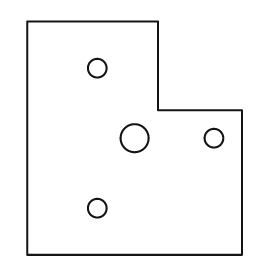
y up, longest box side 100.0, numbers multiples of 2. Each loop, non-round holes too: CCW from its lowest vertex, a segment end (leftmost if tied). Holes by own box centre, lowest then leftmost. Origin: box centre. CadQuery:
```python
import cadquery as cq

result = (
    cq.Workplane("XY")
    .moveTo(-46.0, -50.0)
    .lineTo(46.0, -50.0)
    .lineTo(46.0, 12.0)
    .lineTo(10.0, 12.0)
    .lineTo(10.0, 50.0)
    .lineTo(-46.0, 50.0)
    .close()
    .moveTo(-16.0, -30.0)
    .circle(4.0)
    .moveTo(0.0, 0.0)
    .circle(6.0)
    .moveTo(34.0, 0.0)
    .circle(4.0)
    .moveTo(-16.0, 30.0)
    .circle(4.0)
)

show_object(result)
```